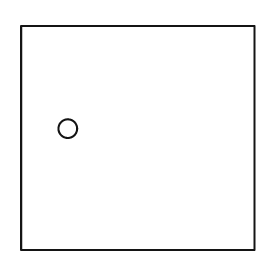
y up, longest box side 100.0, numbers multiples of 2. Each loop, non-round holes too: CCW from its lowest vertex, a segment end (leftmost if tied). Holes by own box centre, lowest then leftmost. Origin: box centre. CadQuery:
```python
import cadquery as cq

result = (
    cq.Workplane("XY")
    .moveTo(-50.0, -48.0)
    .lineTo(50.0, -48.0)
    .lineTo(50.0, 48.0)
    .lineTo(-50.0, 48.0)
    .close()
    .moveTo(-30.0, 4.0)
    .circle(4.0)
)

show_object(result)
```